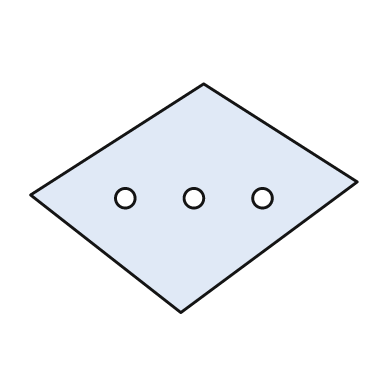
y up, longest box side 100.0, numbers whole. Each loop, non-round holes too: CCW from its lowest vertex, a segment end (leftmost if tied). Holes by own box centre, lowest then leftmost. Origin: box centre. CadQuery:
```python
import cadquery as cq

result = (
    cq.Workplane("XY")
    .moveTo(-4.0, -35.0)
    .lineTo(50.0, 5.0)
    .lineTo(3.0, 35.0)
    .lineTo(-50.0, 1.0)
    .close()
    .moveTo(-21.0, 0.0)
    .circle(3.0)
    .moveTo(0.0, 0.0)
    .circle(3.0)
    .moveTo(21.0, 0.0)
    .circle(3.0)
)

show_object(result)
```